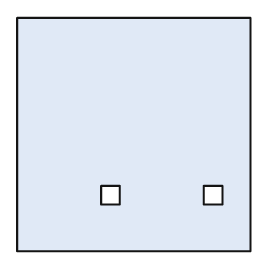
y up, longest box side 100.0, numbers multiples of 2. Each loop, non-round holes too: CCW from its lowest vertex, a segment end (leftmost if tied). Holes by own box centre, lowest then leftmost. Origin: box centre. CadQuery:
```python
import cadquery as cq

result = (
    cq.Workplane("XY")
    .moveTo(-50.0, -50.0)
    .lineTo(50.0, -50.0)
    .lineTo(50.0, 50.0)
    .lineTo(-50.0, 50.0)
    .close()
    .moveTo(-14.0, -30.0)
    .lineTo(-6.0, -30.0)
    .lineTo(-6.0, -22.0)
    .lineTo(-14.0, -22.0)
    .close()
    .moveTo(30.0, -30.0)
    .lineTo(38.0, -30.0)
    .lineTo(38.0, -22.0)
    .lineTo(30.0, -22.0)
    .close()
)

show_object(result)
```